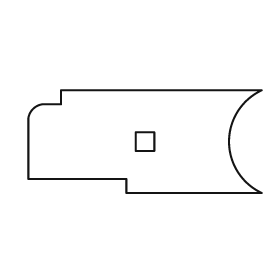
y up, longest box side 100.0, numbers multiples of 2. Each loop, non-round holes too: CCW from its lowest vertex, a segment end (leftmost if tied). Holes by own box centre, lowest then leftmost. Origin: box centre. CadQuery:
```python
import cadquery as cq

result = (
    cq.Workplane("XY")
    .moveTo(-8.0, -22.0)
    .lineTo(50.0, -22.0)
    .threePointArc((36.0, 0.0), (50.0, 22.0))
    .lineTo(-36.0, 22.0)
    .lineTo(-36.0, 16.0)
    .lineTo(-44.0, 16.0)
    .threePointArc((-48.0, 14.0), (-50.0, 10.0))
    .lineTo(-50.0, -16.0)
    .lineTo(-8.0, -16.0)
    .close()
    .moveTo(-4.0, -4.0)
    .lineTo(4.0, -4.0)
    .lineTo(4.0, 4.0)
    .lineTo(-4.0, 4.0)
    .close()
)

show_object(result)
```